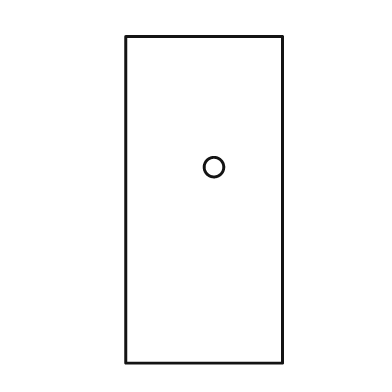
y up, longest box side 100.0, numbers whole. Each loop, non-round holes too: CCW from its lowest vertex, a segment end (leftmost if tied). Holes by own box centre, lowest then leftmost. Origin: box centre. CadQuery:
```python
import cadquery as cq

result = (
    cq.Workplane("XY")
    .moveTo(-24.0, -50.0)
    .lineTo(24.0, -50.0)
    .lineTo(24.0, 50.0)
    .lineTo(-24.0, 50.0)
    .close()
    .moveTo(3.0, 10.0)
    .circle(3.0)
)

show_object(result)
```